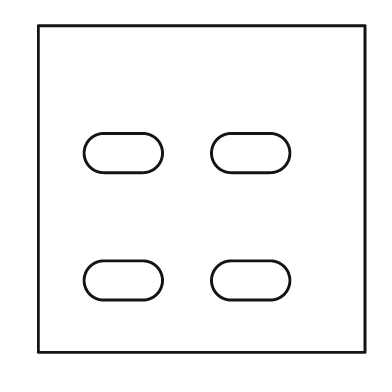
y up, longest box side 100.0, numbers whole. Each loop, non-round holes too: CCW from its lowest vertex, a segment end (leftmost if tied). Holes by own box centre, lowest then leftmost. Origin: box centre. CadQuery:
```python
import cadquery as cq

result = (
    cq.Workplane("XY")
    .moveTo(-50.0, -50.0)
    .lineTo(50.0, -50.0)
    .lineTo(50.0, 50.0)
    .lineTo(-50.0, 50.0)
    .close()
    .moveTo(-30.0, -34.0)
    .lineTo(-18.0, -34.0)
    .threePointArc((-12.0, -28.0), (-18.0, -22.0))
    .lineTo(-30.0, -22.0)
    .threePointArc((-36.0, -28.0), (-30.0, -34.0))
    .close()
    .moveTo(9.0, -34.0)
    .lineTo(21.0, -34.0)
    .threePointArc((27.0, -28.0), (21.0, -22.0))
    .lineTo(9.0, -22.0)
    .threePointArc((3.0, -28.0), (9.0, -34.0))
    .close()
    .moveTo(-30.0, 5.0)
    .lineTo(-18.0, 5.0)
    .threePointArc((-12.0, 11.0), (-18.0, 17.0))
    .lineTo(-30.0, 17.0)
    .threePointArc((-36.0, 11.0), (-30.0, 5.0))
    .close()
    .moveTo(9.0, 5.0)
    .lineTo(21.0, 5.0)
    .threePointArc((27.0, 11.0), (21.0, 17.0))
    .lineTo(9.0, 17.0)
    .threePointArc((3.0, 11.0), (9.0, 5.0))
    .close()
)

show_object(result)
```